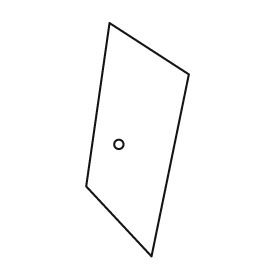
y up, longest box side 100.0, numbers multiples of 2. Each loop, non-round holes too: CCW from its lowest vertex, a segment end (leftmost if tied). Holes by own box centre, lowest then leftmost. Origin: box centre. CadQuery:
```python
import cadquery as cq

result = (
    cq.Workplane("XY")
    .moveTo(6.0, -50.0)
    .lineTo(22.0, 28.0)
    .lineTo(-12.0, 50.0)
    .lineTo(-22.0, -20.0)
    .close()
    .moveTo(-8.0, -2.0)
    .circle(2.0)
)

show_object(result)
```